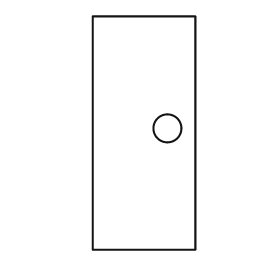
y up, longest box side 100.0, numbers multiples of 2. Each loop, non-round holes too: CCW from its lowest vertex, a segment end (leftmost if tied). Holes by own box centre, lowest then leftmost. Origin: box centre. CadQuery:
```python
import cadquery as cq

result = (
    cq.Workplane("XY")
    .moveTo(-22.0, -50.0)
    .lineTo(22.0, -50.0)
    .lineTo(22.0, 50.0)
    .lineTo(-22.0, 50.0)
    .close()
    .moveTo(10.0, 2.0)
    .circle(6.0)
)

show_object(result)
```